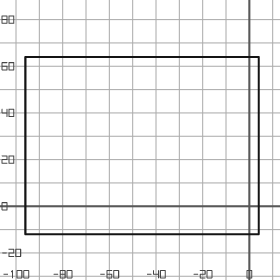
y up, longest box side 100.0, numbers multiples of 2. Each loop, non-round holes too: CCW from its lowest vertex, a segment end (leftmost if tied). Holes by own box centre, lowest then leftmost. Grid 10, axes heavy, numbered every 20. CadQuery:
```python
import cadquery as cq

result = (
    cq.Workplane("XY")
    .moveTo(-96.0, -12.0)
    .lineTo(4.0, -12.0)
    .lineTo(4.0, 64.0)
    .lineTo(-96.0, 64.0)
    .close()
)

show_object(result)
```